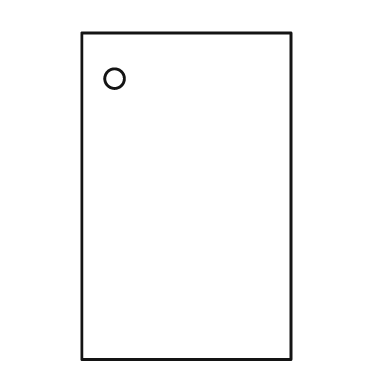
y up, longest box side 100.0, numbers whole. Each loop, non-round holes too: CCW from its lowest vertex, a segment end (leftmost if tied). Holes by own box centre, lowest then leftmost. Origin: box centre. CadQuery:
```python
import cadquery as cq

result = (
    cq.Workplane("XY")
    .moveTo(-32.0, -50.0)
    .lineTo(32.0, -50.0)
    .lineTo(32.0, 50.0)
    .lineTo(-32.0, 50.0)
    .close()
    .moveTo(-22.0, 36.0)
    .circle(3.0)
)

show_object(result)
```